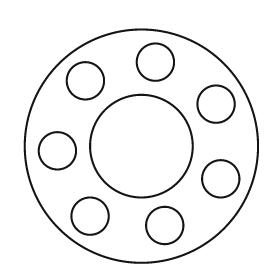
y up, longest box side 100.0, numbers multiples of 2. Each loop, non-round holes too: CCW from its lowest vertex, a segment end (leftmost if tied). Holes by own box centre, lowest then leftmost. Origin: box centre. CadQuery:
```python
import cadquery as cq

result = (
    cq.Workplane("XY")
    .moveTo(0.0, 0.0)
    .circle(50.0)
    .moveTo(10.0, -34.0)
    .circle(8.0)
    .moveTo(-22.0, -30.0)
    .circle(8.0)
    .moveTo(34.0, -14.0)
    .circle(8.0)
    .moveTo(-36.0, -2.0)
    .circle(8.0)
    .moveTo(0.0, 0.0)
    .circle(22.0)
    .moveTo(32.0, 18.0)
    .circle(8.0)
    .moveTo(-24.0, 28.0)
    .circle(8.0)
    .moveTo(6.0, 36.0)
    .circle(8.0)
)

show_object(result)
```